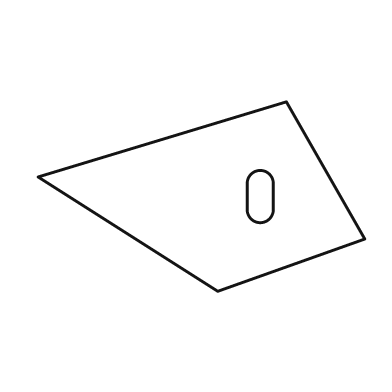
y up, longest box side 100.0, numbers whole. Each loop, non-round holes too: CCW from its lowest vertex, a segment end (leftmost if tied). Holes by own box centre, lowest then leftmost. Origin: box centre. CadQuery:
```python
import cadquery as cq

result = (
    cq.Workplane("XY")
    .moveTo(5.0, -29.0)
    .lineTo(50.0, -13.0)
    .lineTo(26.0, 29.0)
    .lineTo(-50.0, 6.0)
    .close()
    .moveTo(14.0, -4.0)
    .threePointArc((18.0, -8.0), (22.0, -4.0))
    .lineTo(22.0, 4.0)
    .threePointArc((18.0, 8.0), (14.0, 4.0))
    .close()
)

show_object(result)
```